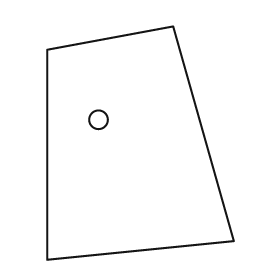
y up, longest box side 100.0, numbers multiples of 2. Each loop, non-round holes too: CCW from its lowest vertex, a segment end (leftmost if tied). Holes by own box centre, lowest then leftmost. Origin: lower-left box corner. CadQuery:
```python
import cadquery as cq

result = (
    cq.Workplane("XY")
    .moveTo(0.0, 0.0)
    .lineTo(80.0, 8.0)
    .lineTo(54.0, 100.0)
    .lineTo(0.0, 90.0)
    .close()
    .moveTo(22.0, 60.0)
    .circle(4.0)
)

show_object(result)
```